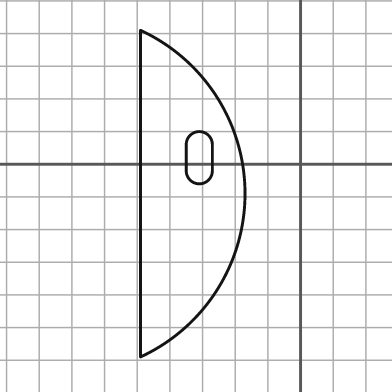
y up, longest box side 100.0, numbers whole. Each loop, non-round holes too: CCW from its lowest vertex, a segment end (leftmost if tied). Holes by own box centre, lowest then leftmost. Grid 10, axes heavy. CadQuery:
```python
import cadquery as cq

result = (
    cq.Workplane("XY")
    .moveTo(-49.0, -59.0)
    .threePointArc((-17.0, -9.0), (-49.0, 41.0))
    .close()
    .moveTo(-35.0, -2.0)
    .threePointArc((-31.0, -6.0), (-27.0, -2.0))
    .lineTo(-27.0, 6.0)
    .threePointArc((-31.0, 10.0), (-35.0, 6.0))
    .close()
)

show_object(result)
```